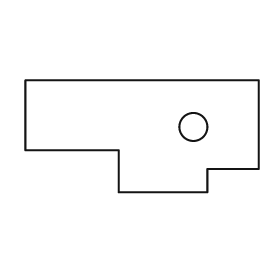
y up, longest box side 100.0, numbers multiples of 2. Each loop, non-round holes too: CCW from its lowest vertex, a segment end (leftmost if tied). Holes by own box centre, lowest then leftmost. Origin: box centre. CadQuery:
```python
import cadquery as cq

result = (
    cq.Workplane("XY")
    .moveTo(-10.0, -24.0)
    .lineTo(28.0, -24.0)
    .lineTo(28.0, -14.0)
    .lineTo(50.0, -14.0)
    .lineTo(50.0, 24.0)
    .lineTo(-50.0, 24.0)
    .lineTo(-50.0, -6.0)
    .lineTo(-10.0, -6.0)
    .close()
    .moveTo(22.0, 4.0)
    .circle(6.0)
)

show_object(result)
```